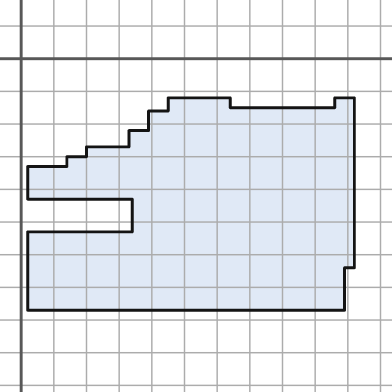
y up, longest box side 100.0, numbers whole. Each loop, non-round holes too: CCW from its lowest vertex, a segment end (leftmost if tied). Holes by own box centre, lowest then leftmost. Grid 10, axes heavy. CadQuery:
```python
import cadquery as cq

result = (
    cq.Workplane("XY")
    .moveTo(2.0, -77.0)
    .lineTo(99.0, -77.0)
    .lineTo(99.0, -64.0)
    .lineTo(102.0, -64.0)
    .lineTo(102.0, -12.0)
    .lineTo(96.0, -12.0)
    .lineTo(96.0, -15.0)
    .lineTo(64.0, -15.0)
    .lineTo(64.0, -12.0)
    .lineTo(45.0, -12.0)
    .lineTo(45.0, -16.0)
    .lineTo(39.0, -16.0)
    .lineTo(39.0, -22.0)
    .lineTo(33.0, -22.0)
    .lineTo(33.0, -27.0)
    .lineTo(20.0, -27.0)
    .lineTo(20.0, -30.0)
    .lineTo(14.0, -30.0)
    .lineTo(14.0, -33.0)
    .lineTo(2.0, -33.0)
    .lineTo(2.0, -43.0)
    .lineTo(34.0, -43.0)
    .lineTo(34.0, -53.0)
    .lineTo(2.0, -53.0)
    .close()
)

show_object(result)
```